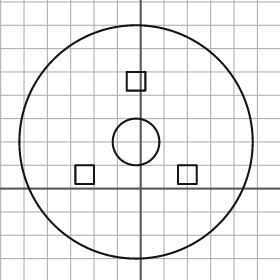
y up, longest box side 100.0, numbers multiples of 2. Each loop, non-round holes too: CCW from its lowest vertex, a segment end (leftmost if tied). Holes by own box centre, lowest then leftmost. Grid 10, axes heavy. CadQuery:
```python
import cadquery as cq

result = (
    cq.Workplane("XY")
    .moveTo(-2.0, 20.0)
    .circle(50.0)
    .moveTo(-28.0, 2.0)
    .lineTo(-20.0, 2.0)
    .lineTo(-20.0, 10.0)
    .lineTo(-28.0, 10.0)
    .close()
    .moveTo(16.0, 2.0)
    .lineTo(24.0, 2.0)
    .lineTo(24.0, 10.0)
    .lineTo(16.0, 10.0)
    .close()
    .moveTo(-2.0, 20.0)
    .circle(10.0)
    .moveTo(-6.0, 42.0)
    .lineTo(2.0, 42.0)
    .lineTo(2.0, 50.0)
    .lineTo(-6.0, 50.0)
    .close()
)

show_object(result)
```